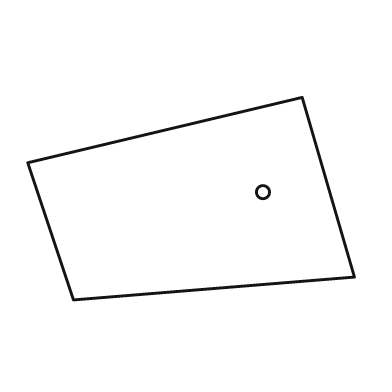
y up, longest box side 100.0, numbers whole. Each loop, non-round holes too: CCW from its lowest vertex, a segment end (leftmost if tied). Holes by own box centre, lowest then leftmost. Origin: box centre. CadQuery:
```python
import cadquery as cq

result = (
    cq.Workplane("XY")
    .moveTo(-36.0, -31.0)
    .lineTo(50.0, -24.0)
    .lineTo(34.0, 31.0)
    .lineTo(-50.0, 11.0)
    .close()
    .moveTo(22.0, 2.0)
    .circle(2.0)
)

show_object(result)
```